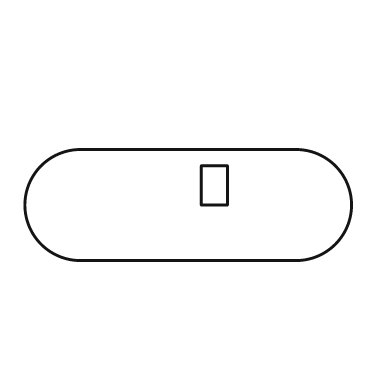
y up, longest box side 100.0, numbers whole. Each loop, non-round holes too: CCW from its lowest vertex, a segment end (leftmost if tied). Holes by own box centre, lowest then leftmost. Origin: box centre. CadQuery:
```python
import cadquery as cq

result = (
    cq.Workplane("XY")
    .moveTo(-33.0, -17.0)
    .lineTo(33.0, -17.0)
    .threePointArc((50.0, 0.0), (33.0, 17.0))
    .lineTo(-33.0, 17.0)
    .threePointArc((-50.0, 0.0), (-33.0, -17.0))
    .close()
    .moveTo(4.0, 0.0)
    .lineTo(12.0, 0.0)
    .lineTo(12.0, 12.0)
    .lineTo(4.0, 12.0)
    .close()
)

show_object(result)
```